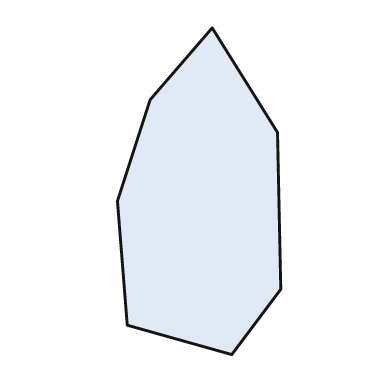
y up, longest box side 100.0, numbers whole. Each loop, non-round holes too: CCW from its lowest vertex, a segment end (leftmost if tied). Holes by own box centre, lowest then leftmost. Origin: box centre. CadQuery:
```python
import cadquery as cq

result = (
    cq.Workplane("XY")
    .moveTo(10.0, -50.0)
    .lineTo(25.0, -30.0)
    .lineTo(24.0, 18.0)
    .lineTo(4.0, 50.0)
    .lineTo(-15.0, 28.0)
    .lineTo(-25.0, -3.0)
    .lineTo(-22.0, -41.0)
    .close()
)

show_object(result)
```